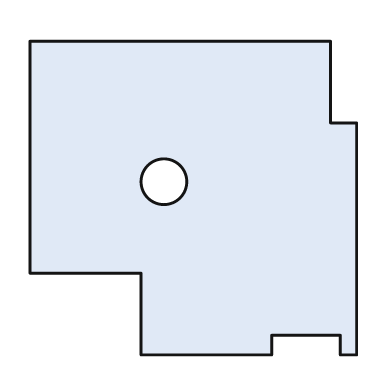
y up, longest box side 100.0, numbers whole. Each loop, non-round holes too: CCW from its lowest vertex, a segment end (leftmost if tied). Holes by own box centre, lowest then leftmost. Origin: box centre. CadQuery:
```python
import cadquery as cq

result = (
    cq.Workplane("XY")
    .moveTo(-16.0, -48.0)
    .lineTo(24.0, -48.0)
    .lineTo(24.0, -42.0)
    .lineTo(45.0, -42.0)
    .lineTo(45.0, -48.0)
    .lineTo(50.0, -48.0)
    .lineTo(50.0, 23.0)
    .lineTo(42.0, 23.0)
    .lineTo(42.0, 48.0)
    .lineTo(-50.0, 48.0)
    .lineTo(-50.0, -23.0)
    .lineTo(-16.0, -23.0)
    .close()
    .moveTo(-9.0, 5.0)
    .circle(7.0)
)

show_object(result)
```